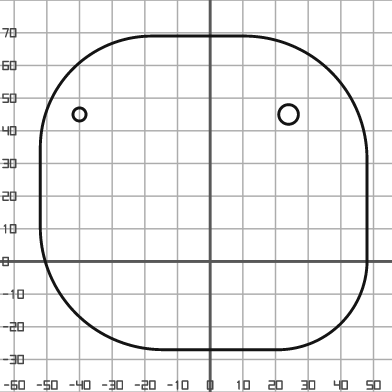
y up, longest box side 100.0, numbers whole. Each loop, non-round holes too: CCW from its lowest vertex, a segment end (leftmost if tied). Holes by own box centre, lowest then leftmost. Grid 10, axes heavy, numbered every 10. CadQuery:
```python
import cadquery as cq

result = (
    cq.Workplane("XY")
    .moveTo(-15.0, -27.0)
    .lineTo(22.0, -27.0)
    .threePointArc((40.0, -19.0), (48.0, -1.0))
    .lineTo(48.0, 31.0)
    .threePointArc((37.0, 58.0), (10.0, 69.0))
    .lineTo(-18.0, 69.0)
    .threePointArc((-42.0, 59.0), (-52.0, 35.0))
    .lineTo(-52.0, 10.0)
    .threePointArc((-41.0, -16.0), (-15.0, -27.0))
    .close()
    .moveTo(-40.0, 45.0)
    .circle(2.0)
    .moveTo(24.0, 45.0)
    .circle(3.0)
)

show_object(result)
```